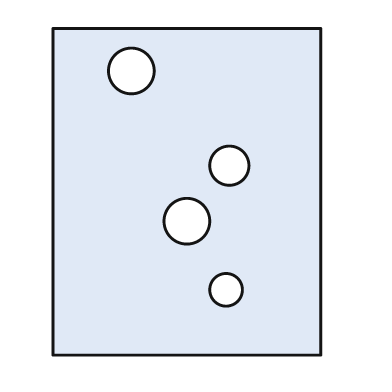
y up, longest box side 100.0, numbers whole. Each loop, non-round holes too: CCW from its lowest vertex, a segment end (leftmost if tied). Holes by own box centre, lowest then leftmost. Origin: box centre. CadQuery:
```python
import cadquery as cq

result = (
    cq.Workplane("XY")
    .moveTo(-41.0, -50.0)
    .lineTo(41.0, -50.0)
    .lineTo(41.0, 50.0)
    .lineTo(-41.0, 50.0)
    .close()
    .moveTo(12.0, -30.0)
    .circle(5.0)
    .moveTo(0.0, -9.0)
    .circle(7.0)
    .moveTo(13.0, 8.0)
    .circle(6.0)
    .moveTo(-17.0, 37.0)
    .circle(7.0)
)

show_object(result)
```